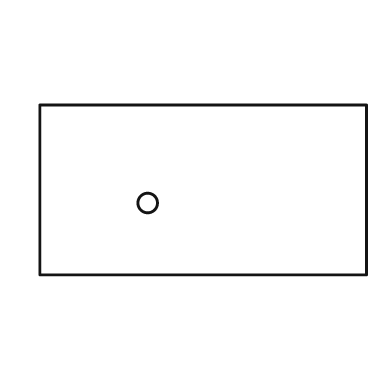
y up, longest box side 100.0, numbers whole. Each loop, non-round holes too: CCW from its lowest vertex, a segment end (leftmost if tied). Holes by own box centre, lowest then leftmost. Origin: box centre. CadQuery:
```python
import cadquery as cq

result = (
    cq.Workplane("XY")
    .moveTo(-50.0, -26.0)
    .lineTo(50.0, -26.0)
    .lineTo(50.0, 26.0)
    .lineTo(-50.0, 26.0)
    .close()
    .moveTo(-17.0, -4.0)
    .circle(3.0)
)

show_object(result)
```